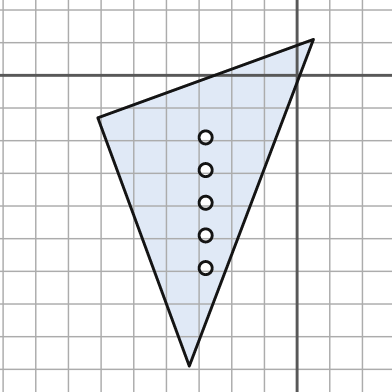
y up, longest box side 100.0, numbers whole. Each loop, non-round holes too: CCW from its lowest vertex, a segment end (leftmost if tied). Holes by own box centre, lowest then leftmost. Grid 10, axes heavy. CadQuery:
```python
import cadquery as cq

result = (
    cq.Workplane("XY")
    .moveTo(-33.0, -89.0)
    .lineTo(5.0, 11.0)
    .lineTo(-61.0, -13.0)
    .close()
    .moveTo(-28.0, -59.0)
    .circle(2.0)
    .moveTo(-28.0, -49.0)
    .circle(2.0)
    .moveTo(-28.0, -39.0)
    .circle(2.0)
    .moveTo(-28.0, -29.0)
    .circle(2.0)
    .moveTo(-28.0, -19.0)
    .circle(2.0)
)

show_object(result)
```